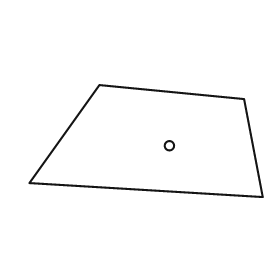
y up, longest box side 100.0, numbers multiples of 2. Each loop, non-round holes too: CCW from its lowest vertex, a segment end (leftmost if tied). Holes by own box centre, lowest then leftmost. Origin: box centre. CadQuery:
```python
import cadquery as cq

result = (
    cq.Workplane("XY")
    .moveTo(50.0, -24.0)
    .lineTo(42.0, 18.0)
    .lineTo(-20.0, 24.0)
    .lineTo(-50.0, -18.0)
    .close()
    .moveTo(10.0, -2.0)
    .circle(2.0)
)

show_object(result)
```